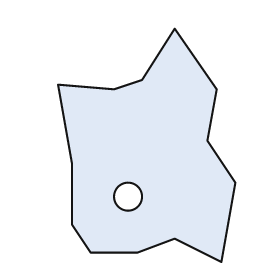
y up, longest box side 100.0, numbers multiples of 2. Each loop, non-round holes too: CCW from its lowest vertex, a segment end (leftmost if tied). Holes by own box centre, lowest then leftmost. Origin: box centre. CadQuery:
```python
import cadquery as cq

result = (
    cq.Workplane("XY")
    .moveTo(32.0, -50.0)
    .lineTo(38.0, -16.0)
    .lineTo(26.0, 2.0)
    .lineTo(30.0, 24.0)
    .lineTo(12.0, 50.0)
    .lineTo(-2.0, 28.0)
    .lineTo(-14.0, 24.0)
    .lineTo(-38.0, 26.0)
    .lineTo(-32.0, -8.0)
    .lineTo(-32.0, -34.0)
    .lineTo(-24.0, -46.0)
    .lineTo(-4.0, -46.0)
    .lineTo(12.0, -40.0)
    .close()
    .moveTo(-8.0, -22.0)
    .circle(6.0)
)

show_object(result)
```